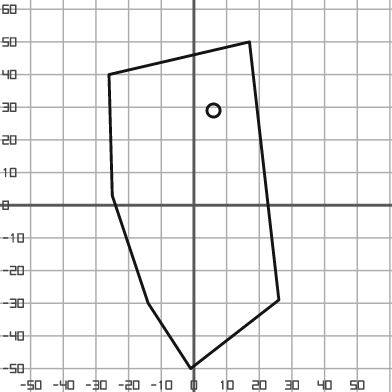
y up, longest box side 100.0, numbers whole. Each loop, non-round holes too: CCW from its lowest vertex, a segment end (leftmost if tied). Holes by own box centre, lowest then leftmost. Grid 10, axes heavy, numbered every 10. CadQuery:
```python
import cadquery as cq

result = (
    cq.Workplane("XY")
    .moveTo(-1.0, -50.0)
    .lineTo(26.0, -29.0)
    .lineTo(17.0, 50.0)
    .lineTo(-26.0, 40.0)
    .lineTo(-25.0, 3.0)
    .lineTo(-14.0, -30.0)
    .close()
    .moveTo(6.0, 29.0)
    .circle(2.0)
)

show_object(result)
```